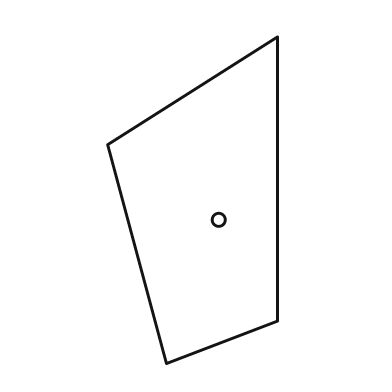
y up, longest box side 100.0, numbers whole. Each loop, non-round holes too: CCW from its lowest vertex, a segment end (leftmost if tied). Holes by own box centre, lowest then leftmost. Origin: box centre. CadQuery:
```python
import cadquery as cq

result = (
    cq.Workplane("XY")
    .moveTo(-8.0, -50.0)
    .lineTo(26.0, -37.0)
    .lineTo(26.0, 50.0)
    .lineTo(-26.0, 17.0)
    .close()
    .moveTo(8.0, -6.0)
    .circle(2.0)
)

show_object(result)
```